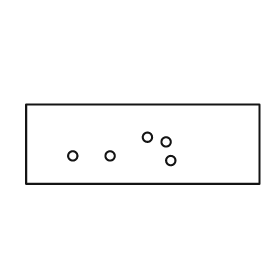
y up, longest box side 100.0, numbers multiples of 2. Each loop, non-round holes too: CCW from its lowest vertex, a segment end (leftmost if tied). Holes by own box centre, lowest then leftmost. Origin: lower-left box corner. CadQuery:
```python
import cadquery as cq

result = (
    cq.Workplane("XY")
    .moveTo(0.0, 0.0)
    .lineTo(100.0, 0.0)
    .lineTo(100.0, 34.0)
    .lineTo(0.0, 34.0)
    .close()
    .moveTo(62.0, 10.0)
    .circle(2.0)
    .moveTo(20.0, 12.0)
    .circle(2.0)
    .moveTo(36.0, 12.0)
    .circle(2.0)
    .moveTo(60.0, 18.0)
    .circle(2.0)
    .moveTo(52.0, 20.0)
    .circle(2.0)
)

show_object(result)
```